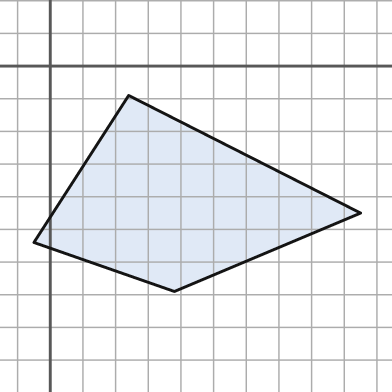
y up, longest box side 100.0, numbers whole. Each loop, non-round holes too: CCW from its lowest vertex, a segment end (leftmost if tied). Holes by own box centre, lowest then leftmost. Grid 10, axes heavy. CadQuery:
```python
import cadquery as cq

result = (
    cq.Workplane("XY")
    .moveTo(38.0, -69.0)
    .lineTo(95.0, -45.0)
    .lineTo(24.0, -9.0)
    .lineTo(-5.0, -54.0)
    .close()
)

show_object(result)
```